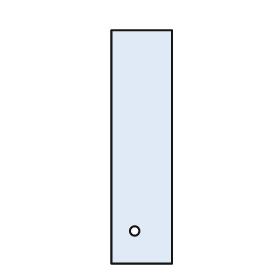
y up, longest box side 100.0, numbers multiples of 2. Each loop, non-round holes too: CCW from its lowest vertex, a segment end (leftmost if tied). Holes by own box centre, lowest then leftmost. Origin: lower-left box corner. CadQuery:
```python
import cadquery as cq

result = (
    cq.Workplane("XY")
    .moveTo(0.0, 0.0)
    .lineTo(26.0, 0.0)
    .lineTo(26.0, 100.0)
    .lineTo(0.0, 100.0)
    .close()
    .moveTo(10.0, 14.0)
    .circle(2.0)
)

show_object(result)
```